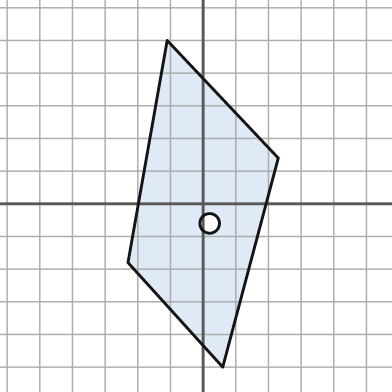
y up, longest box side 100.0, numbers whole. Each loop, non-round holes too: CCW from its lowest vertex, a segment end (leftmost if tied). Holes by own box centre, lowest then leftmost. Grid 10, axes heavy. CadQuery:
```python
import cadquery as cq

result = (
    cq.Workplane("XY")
    .moveTo(6.0, -50.0)
    .lineTo(23.0, 14.0)
    .lineTo(-11.0, 50.0)
    .lineTo(-23.0, -18.0)
    .close()
    .moveTo(2.0, -6.0)
    .circle(3.0)
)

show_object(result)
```